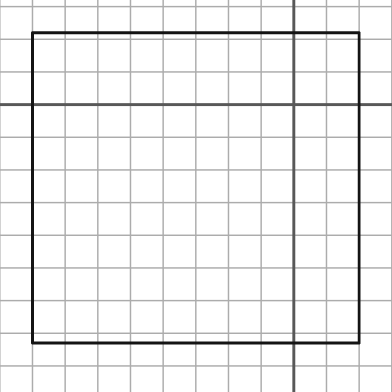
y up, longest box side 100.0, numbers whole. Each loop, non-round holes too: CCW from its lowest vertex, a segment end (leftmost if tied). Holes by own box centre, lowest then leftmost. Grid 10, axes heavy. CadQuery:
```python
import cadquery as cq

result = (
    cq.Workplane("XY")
    .moveTo(-80.0, -73.0)
    .lineTo(20.0, -73.0)
    .lineTo(20.0, 22.0)
    .lineTo(-80.0, 22.0)
    .close()
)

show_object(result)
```